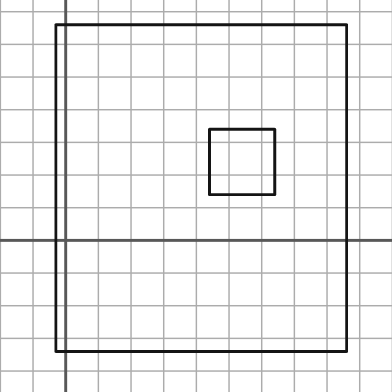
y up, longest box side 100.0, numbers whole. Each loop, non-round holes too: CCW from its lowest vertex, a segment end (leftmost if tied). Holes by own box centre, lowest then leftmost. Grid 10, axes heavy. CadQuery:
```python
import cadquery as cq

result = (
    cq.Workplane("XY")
    .moveTo(-3.0, -34.0)
    .lineTo(86.0, -34.0)
    .lineTo(86.0, 66.0)
    .lineTo(-3.0, 66.0)
    .close()
    .moveTo(44.0, 14.0)
    .lineTo(64.0, 14.0)
    .lineTo(64.0, 34.0)
    .lineTo(44.0, 34.0)
    .close()
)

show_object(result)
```